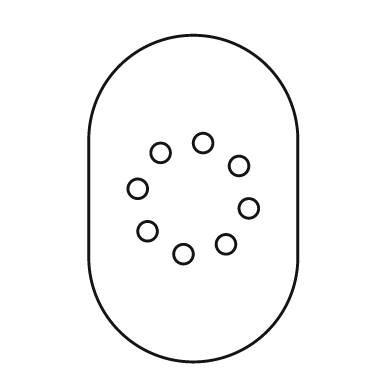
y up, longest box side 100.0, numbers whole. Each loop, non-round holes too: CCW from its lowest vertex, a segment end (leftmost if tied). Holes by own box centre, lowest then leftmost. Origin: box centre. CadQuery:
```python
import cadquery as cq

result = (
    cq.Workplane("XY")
    .moveTo(-32.0, -18.0)
    .threePointArc((0.0, -50.0), (32.0, -18.0))
    .lineTo(32.0, 18.0)
    .threePointArc((0.0, 50.0), (-32.0, 18.0))
    .close()
    .moveTo(-3.0, -17.0)
    .circle(3.0)
    .moveTo(10.0, -14.0)
    .circle(3.0)
    .moveTo(-14.0, -10.0)
    .circle(3.0)
    .moveTo(17.0, -3.0)
    .circle(3.0)
    .moveTo(-17.0, 3.0)
    .circle(3.0)
    .moveTo(14.0, 10.0)
    .circle(3.0)
    .moveTo(-10.0, 14.0)
    .circle(3.0)
    .moveTo(3.0, 17.0)
    .circle(3.0)
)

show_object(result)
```